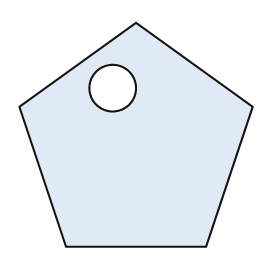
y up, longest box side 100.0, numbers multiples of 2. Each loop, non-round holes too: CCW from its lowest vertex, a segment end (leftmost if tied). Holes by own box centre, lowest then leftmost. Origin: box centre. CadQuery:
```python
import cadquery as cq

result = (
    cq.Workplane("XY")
    .moveTo(-30.0, -48.0)
    .lineTo(30.0, -48.0)
    .lineTo(50.0, 12.0)
    .lineTo(0.0, 48.0)
    .lineTo(-50.0, 12.0)
    .close()
    .moveTo(-10.0, 20.0)
    .circle(10.0)
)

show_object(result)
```